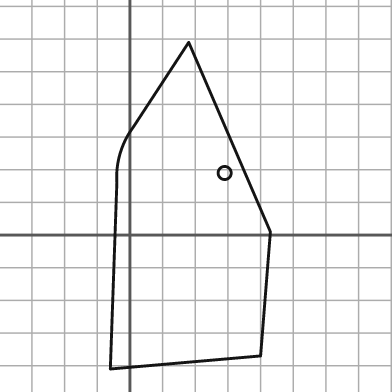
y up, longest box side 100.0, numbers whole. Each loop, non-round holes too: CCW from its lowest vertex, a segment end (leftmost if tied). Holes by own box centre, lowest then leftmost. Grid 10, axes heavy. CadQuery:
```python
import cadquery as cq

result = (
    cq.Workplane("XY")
    .moveTo(-6.0, -41.0)
    .lineTo(40.0, -37.0)
    .lineTo(43.0, 1.0)
    .lineTo(18.0, 59.0)
    .lineTo(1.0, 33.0)
    .threePointArc((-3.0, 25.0), (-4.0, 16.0))
    .close()
    .moveTo(29.0, 19.0)
    .circle(2.0)
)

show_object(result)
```